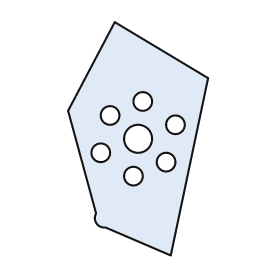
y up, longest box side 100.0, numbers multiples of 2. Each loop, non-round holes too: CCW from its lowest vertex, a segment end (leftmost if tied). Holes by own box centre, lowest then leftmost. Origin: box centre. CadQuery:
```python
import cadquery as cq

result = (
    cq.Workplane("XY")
    .moveTo(14.0, -50.0)
    .lineTo(30.0, 26.0)
    .lineTo(-10.0, 50.0)
    .lineTo(-30.0, 12.0)
    .lineTo(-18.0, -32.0)
    .threePointArc((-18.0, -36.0), (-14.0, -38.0))
    .close()
    .moveTo(-2.0, -16.0)
    .circle(4.0)
    .moveTo(12.0, -10.0)
    .circle(4.0)
    .moveTo(-16.0, -6.0)
    .circle(4.0)
    .moveTo(0.0, 0.0)
    .circle(6.0)
    .moveTo(16.0, 6.0)
    .circle(4.0)
    .moveTo(-12.0, 10.0)
    .circle(4.0)
    .moveTo(2.0, 16.0)
    .circle(4.0)
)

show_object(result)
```